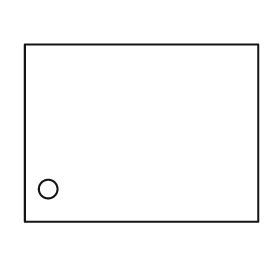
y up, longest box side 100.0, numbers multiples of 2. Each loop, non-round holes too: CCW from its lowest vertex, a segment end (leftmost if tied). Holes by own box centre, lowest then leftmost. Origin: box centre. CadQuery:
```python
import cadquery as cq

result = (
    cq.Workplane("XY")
    .moveTo(-50.0, -38.0)
    .lineTo(50.0, -38.0)
    .lineTo(50.0, 38.0)
    .lineTo(-50.0, 38.0)
    .close()
    .moveTo(-40.0, -24.0)
    .circle(4.0)
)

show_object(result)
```